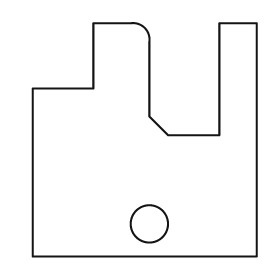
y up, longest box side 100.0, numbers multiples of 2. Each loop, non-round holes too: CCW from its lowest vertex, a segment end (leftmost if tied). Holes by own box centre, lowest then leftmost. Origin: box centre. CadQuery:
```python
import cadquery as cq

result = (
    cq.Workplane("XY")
    .moveTo(-48.0, -50.0)
    .lineTo(48.0, -50.0)
    .lineTo(48.0, 50.0)
    .lineTo(32.0, 50.0)
    .lineTo(32.0, 2.0)
    .lineTo(10.0, 2.0)
    .lineTo(2.0, 10.0)
    .lineTo(2.0, 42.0)
    .threePointArc((0.0, 48.0), (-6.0, 50.0))
    .lineTo(-22.0, 50.0)
    .lineTo(-22.0, 22.0)
    .lineTo(-48.0, 22.0)
    .close()
    .moveTo(2.0, -36.0)
    .circle(8.0)
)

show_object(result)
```